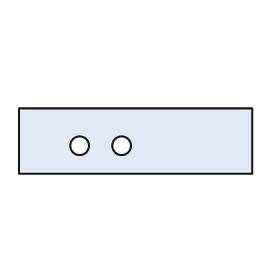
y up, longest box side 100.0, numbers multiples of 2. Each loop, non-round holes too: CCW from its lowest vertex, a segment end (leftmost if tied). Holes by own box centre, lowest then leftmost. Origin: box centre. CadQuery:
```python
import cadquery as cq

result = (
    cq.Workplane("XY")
    .moveTo(-50.0, -14.0)
    .lineTo(50.0, -14.0)
    .lineTo(50.0, 14.0)
    .lineTo(-50.0, 14.0)
    .close()
    .moveTo(-24.0, -2.0)
    .circle(4.0)
    .moveTo(-6.0, -2.0)
    .circle(4.0)
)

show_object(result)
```